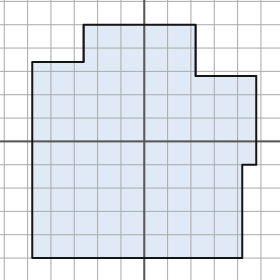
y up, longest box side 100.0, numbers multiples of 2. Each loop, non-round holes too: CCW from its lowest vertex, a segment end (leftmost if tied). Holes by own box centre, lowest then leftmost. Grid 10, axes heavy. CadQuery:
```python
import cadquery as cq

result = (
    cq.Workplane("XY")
    .moveTo(-48.0, -50.0)
    .lineTo(42.0, -50.0)
    .lineTo(42.0, -10.0)
    .lineTo(48.0, -10.0)
    .lineTo(48.0, 28.0)
    .lineTo(22.0, 28.0)
    .lineTo(22.0, 50.0)
    .lineTo(-26.0, 50.0)
    .lineTo(-26.0, 34.0)
    .lineTo(-48.0, 34.0)
    .close()
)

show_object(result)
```